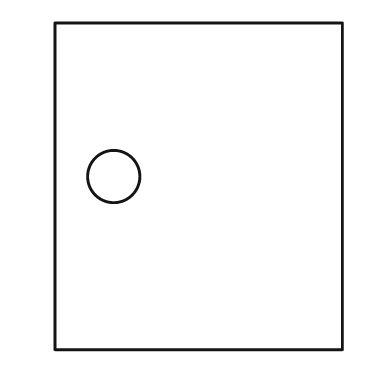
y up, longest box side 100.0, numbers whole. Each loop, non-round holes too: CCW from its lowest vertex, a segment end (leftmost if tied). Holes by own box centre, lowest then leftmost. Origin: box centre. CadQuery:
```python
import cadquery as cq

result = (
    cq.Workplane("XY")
    .moveTo(-44.0, -50.0)
    .lineTo(44.0, -50.0)
    .lineTo(44.0, 50.0)
    .lineTo(-44.0, 50.0)
    .close()
    .moveTo(-26.0, 3.0)
    .circle(8.0)
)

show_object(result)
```